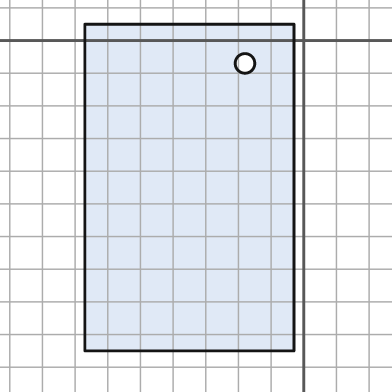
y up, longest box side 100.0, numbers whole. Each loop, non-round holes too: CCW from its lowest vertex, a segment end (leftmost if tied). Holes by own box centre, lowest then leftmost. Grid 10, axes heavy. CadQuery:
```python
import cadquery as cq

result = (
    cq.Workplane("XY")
    .moveTo(-67.0, -95.0)
    .lineTo(-3.0, -95.0)
    .lineTo(-3.0, 5.0)
    .lineTo(-67.0, 5.0)
    .close()
    .moveTo(-18.0, -7.0)
    .circle(3.0)
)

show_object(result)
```